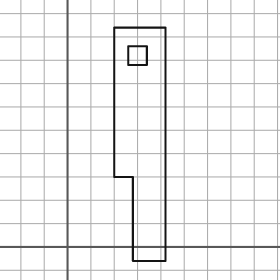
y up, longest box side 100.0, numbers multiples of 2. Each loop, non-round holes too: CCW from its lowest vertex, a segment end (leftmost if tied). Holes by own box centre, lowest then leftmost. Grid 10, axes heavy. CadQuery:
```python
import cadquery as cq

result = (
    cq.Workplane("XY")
    .moveTo(28.0, -6.0)
    .lineTo(42.0, -6.0)
    .lineTo(42.0, 94.0)
    .lineTo(20.0, 94.0)
    .lineTo(20.0, 30.0)
    .lineTo(28.0, 30.0)
    .close()
    .moveTo(26.0, 78.0)
    .lineTo(34.0, 78.0)
    .lineTo(34.0, 86.0)
    .lineTo(26.0, 86.0)
    .close()
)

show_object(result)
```